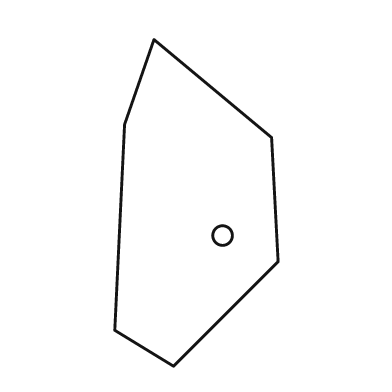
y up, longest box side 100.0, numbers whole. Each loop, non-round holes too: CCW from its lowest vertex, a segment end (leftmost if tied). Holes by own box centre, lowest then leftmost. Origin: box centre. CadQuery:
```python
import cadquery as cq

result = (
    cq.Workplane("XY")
    .moveTo(-7.0, -50.0)
    .lineTo(25.0, -18.0)
    .lineTo(23.0, 20.0)
    .lineTo(-13.0, 50.0)
    .lineTo(-22.0, 24.0)
    .lineTo(-25.0, -39.0)
    .close()
    .moveTo(8.0, -10.0)
    .circle(3.0)
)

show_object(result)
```